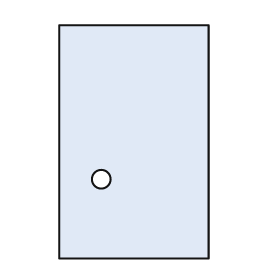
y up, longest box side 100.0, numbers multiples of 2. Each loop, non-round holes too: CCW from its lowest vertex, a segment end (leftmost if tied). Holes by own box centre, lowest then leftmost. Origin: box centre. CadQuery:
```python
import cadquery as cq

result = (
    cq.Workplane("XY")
    .moveTo(-32.0, -50.0)
    .lineTo(32.0, -50.0)
    .lineTo(32.0, 50.0)
    .lineTo(-32.0, 50.0)
    .close()
    .moveTo(-14.0, -16.0)
    .circle(4.0)
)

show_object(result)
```